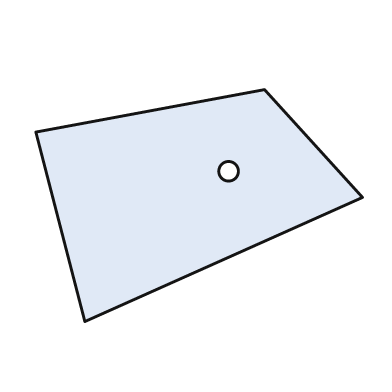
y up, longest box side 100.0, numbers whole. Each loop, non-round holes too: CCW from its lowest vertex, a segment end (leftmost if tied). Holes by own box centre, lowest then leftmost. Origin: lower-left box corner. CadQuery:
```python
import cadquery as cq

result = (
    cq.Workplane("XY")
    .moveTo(15.0, 0.0)
    .lineTo(100.0, 38.0)
    .lineTo(70.0, 71.0)
    .lineTo(0.0, 58.0)
    .close()
    .moveTo(59.0, 46.0)
    .circle(3.0)
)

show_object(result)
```